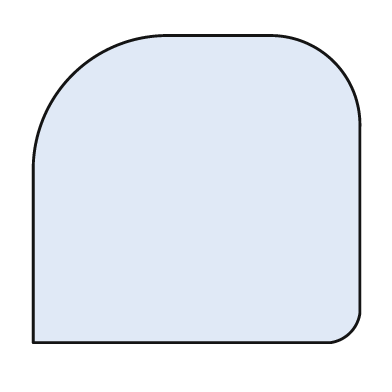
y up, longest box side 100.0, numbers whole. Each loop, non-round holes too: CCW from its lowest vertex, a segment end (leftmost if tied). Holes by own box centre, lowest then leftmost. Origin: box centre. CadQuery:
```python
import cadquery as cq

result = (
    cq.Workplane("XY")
    .moveTo(-50.0, -47.0)
    .lineTo(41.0, -47.0)
    .threePointArc((47.0, -44.0), (50.0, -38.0))
    .lineTo(50.0, 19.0)
    .threePointArc((42.0, 39.0), (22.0, 47.0))
    .lineTo(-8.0, 47.0)
    .threePointArc((-38.0, 35.0), (-50.0, 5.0))
    .close()
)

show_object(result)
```